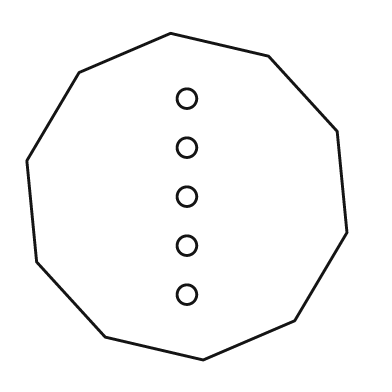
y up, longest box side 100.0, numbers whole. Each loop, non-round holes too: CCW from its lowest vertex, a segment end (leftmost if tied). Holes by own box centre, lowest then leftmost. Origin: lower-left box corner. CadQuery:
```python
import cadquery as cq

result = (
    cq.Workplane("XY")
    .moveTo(54.0, 0.0)
    .lineTo(82.0, 12.0)
    .lineTo(98.0, 39.0)
    .lineTo(95.0, 70.0)
    .lineTo(74.0, 93.0)
    .lineTo(44.0, 100.0)
    .lineTo(16.0, 88.0)
    .lineTo(0.0, 61.0)
    .lineTo(3.0, 30.0)
    .lineTo(24.0, 7.0)
    .close()
    .moveTo(49.0, 20.0)
    .circle(3.0)
    .moveTo(49.0, 35.0)
    .circle(3.0)
    .moveTo(49.0, 50.0)
    .circle(3.0)
    .moveTo(49.0, 65.0)
    .circle(3.0)
    .moveTo(49.0, 80.0)
    .circle(3.0)
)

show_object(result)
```